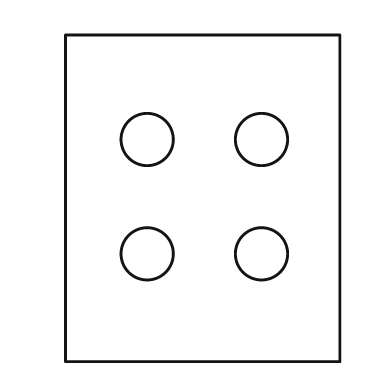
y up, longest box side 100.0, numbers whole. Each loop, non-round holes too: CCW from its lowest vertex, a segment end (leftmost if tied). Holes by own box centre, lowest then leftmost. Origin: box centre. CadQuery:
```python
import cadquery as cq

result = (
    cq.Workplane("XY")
    .moveTo(-42.0, -50.0)
    .lineTo(42.0, -50.0)
    .lineTo(42.0, 50.0)
    .lineTo(-42.0, 50.0)
    .close()
    .moveTo(-17.0, -17.0)
    .circle(8.0)
    .moveTo(18.0, -17.0)
    .circle(8.0)
    .moveTo(-17.0, 18.0)
    .circle(8.0)
    .moveTo(18.0, 18.0)
    .circle(8.0)
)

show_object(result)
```